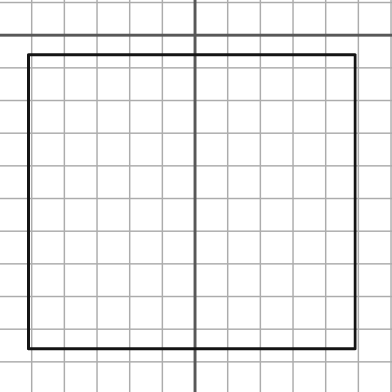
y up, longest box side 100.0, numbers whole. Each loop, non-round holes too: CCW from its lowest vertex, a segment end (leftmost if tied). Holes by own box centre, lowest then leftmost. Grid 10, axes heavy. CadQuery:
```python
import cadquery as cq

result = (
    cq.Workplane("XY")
    .moveTo(-51.0, -96.0)
    .lineTo(49.0, -96.0)
    .lineTo(49.0, -6.0)
    .lineTo(-51.0, -6.0)
    .close()
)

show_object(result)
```